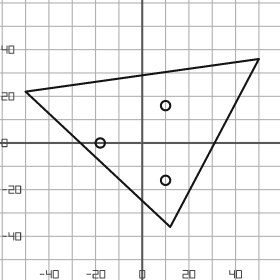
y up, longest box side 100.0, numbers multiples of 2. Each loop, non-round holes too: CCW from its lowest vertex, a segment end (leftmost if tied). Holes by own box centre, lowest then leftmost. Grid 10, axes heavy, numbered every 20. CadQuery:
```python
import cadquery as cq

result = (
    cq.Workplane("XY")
    .moveTo(12.0, -36.0)
    .lineTo(50.0, 36.0)
    .lineTo(-50.0, 22.0)
    .close()
    .moveTo(10.0, -16.0)
    .circle(2.0)
    .moveTo(-18.0, 0.0)
    .circle(2.0)
    .moveTo(10.0, 16.0)
    .circle(2.0)
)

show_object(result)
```